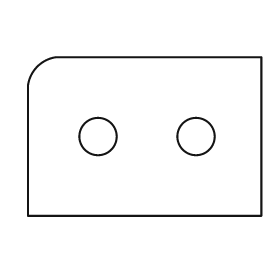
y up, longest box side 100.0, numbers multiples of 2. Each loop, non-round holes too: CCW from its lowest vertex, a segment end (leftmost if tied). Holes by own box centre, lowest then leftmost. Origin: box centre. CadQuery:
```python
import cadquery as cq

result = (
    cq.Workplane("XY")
    .moveTo(-50.0, -34.0)
    .lineTo(50.0, -34.0)
    .lineTo(50.0, 34.0)
    .lineTo(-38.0, 34.0)
    .threePointArc((-46.0, 30.0), (-50.0, 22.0))
    .close()
    .moveTo(-20.0, 0.0)
    .circle(8.0)
    .moveTo(22.0, 0.0)
    .circle(8.0)
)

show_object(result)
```